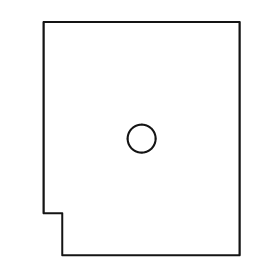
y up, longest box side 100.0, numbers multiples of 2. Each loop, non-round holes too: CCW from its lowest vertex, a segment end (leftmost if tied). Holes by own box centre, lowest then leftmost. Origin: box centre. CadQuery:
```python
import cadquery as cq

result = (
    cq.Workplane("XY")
    .moveTo(-34.0, -50.0)
    .lineTo(42.0, -50.0)
    .lineTo(42.0, 50.0)
    .lineTo(-42.0, 50.0)
    .lineTo(-42.0, -32.0)
    .lineTo(-34.0, -32.0)
    .close()
    .moveTo(0.0, 0.0)
    .circle(6.0)
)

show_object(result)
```